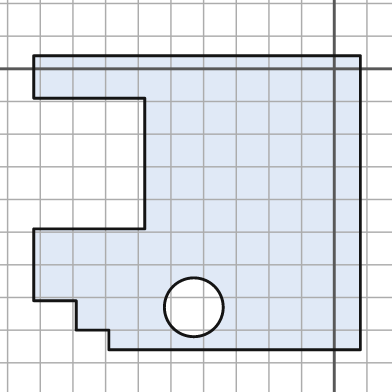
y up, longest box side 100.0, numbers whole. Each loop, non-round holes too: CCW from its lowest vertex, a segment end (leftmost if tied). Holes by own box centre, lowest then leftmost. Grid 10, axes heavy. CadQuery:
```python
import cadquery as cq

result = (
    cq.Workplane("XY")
    .moveTo(-69.0, -86.0)
    .lineTo(8.0, -86.0)
    .lineTo(8.0, 4.0)
    .lineTo(-92.0, 4.0)
    .lineTo(-92.0, -9.0)
    .lineTo(-58.0, -9.0)
    .lineTo(-58.0, -49.0)
    .lineTo(-92.0, -49.0)
    .lineTo(-92.0, -71.0)
    .lineTo(-79.0, -71.0)
    .lineTo(-79.0, -80.0)
    .lineTo(-69.0, -80.0)
    .close()
    .moveTo(-43.0, -73.0)
    .circle(9.0)
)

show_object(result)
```